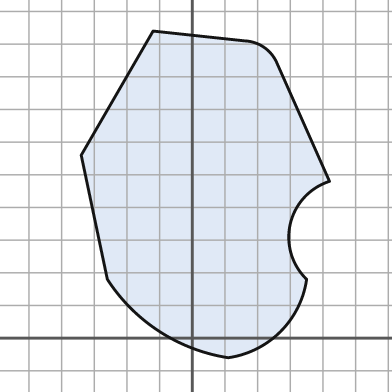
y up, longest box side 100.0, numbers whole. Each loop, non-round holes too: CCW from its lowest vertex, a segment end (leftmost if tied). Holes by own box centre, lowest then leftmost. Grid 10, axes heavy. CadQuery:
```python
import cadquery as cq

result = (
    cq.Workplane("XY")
    .moveTo(11.0, -6.0)
    .threePointArc((27.0, 2.0), (35.0, 18.0))
    .threePointArc((30.0, 35.0), (42.0, 48.0))
    .lineTo(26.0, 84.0)
    .threePointArc((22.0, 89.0), (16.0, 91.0))
    .lineTo(-12.0, 94.0)
    .lineTo(-34.0, 56.0)
    .lineTo(-26.0, 18.0)
    .threePointArc((-10.0, 2.0), (11.0, -6.0))
    .close()
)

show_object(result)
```